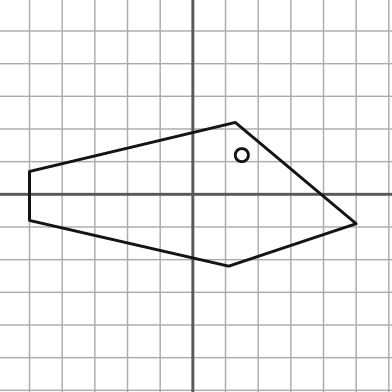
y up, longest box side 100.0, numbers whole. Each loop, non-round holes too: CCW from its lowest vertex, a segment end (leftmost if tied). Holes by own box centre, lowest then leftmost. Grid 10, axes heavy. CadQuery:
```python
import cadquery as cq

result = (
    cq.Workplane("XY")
    .moveTo(11.0, -22.0)
    .lineTo(50.0, -9.0)
    .lineTo(13.0, 22.0)
    .lineTo(-50.0, 7.0)
    .lineTo(-50.0, -8.0)
    .close()
    .moveTo(15.0, 12.0)
    .circle(2.0)
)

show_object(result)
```